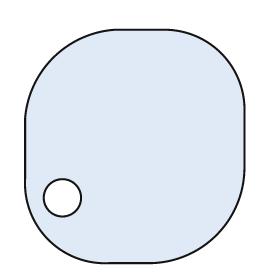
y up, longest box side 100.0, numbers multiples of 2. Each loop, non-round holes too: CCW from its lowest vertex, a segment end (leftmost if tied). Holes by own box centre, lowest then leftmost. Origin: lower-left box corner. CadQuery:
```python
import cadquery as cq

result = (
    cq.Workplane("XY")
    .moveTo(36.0, 0.0)
    .lineTo(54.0, 0.0)
    .threePointArc((82.0, 12.0), (94.0, 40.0))
    .lineTo(94.0, 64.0)
    .threePointArc((84.0, 90.0), (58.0, 100.0))
    .lineTo(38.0, 100.0)
    .threePointArc((12.0, 88.0), (0.0, 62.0))
    .lineTo(0.0, 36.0)
    .threePointArc((10.0, 10.0), (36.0, 0.0))
    .close()
    .moveTo(16.0, 28.0)
    .circle(8.0)
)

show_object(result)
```